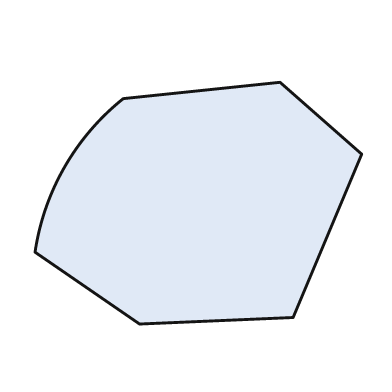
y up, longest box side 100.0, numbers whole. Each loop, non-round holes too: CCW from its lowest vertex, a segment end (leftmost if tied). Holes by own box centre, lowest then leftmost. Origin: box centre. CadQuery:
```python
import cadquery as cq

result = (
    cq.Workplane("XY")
    .moveTo(-18.0, -37.0)
    .lineTo(29.0, -35.0)
    .lineTo(50.0, 15.0)
    .lineTo(25.0, 37.0)
    .lineTo(-23.0, 32.0)
    .threePointArc((-41.0, 11.0), (-50.0, -15.0))
    .close()
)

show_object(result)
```